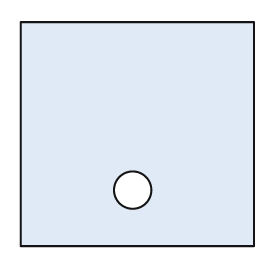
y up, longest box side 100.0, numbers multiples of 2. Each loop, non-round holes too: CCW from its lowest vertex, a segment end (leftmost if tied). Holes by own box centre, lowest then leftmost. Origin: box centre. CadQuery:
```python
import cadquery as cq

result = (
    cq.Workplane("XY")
    .moveTo(-50.0, -48.0)
    .lineTo(50.0, -48.0)
    .lineTo(50.0, 48.0)
    .lineTo(-50.0, 48.0)
    .close()
    .moveTo(-2.0, -24.0)
    .circle(8.0)
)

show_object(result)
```